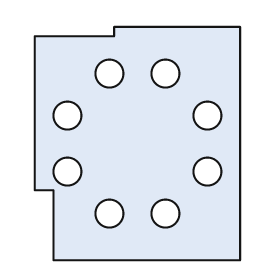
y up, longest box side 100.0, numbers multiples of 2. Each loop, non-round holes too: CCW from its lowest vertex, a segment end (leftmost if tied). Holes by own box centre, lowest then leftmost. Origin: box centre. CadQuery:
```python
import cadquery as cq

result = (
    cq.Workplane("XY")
    .moveTo(-36.0, -50.0)
    .lineTo(44.0, -50.0)
    .lineTo(44.0, 50.0)
    .lineTo(-10.0, 50.0)
    .lineTo(-10.0, 46.0)
    .lineTo(-44.0, 46.0)
    .lineTo(-44.0, -20.0)
    .lineTo(-36.0, -20.0)
    .close()
    .moveTo(-12.0, -30.0)
    .circle(6.0)
    .moveTo(12.0, -30.0)
    .circle(6.0)
    .moveTo(-30.0, -12.0)
    .circle(6.0)
    .moveTo(30.0, -12.0)
    .circle(6.0)
    .moveTo(-30.0, 12.0)
    .circle(6.0)
    .moveTo(30.0, 12.0)
    .circle(6.0)
    .moveTo(-12.0, 30.0)
    .circle(6.0)
    .moveTo(12.0, 30.0)
    .circle(6.0)
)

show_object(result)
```